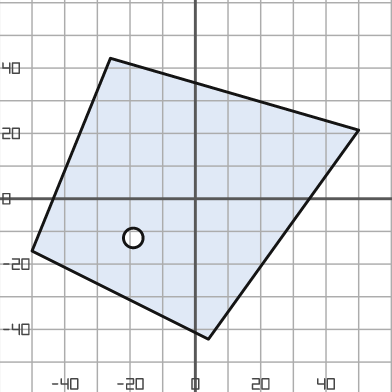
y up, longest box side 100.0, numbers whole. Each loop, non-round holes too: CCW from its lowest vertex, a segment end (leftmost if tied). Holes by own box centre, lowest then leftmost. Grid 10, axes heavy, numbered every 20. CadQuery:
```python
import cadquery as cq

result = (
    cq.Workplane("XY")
    .moveTo(4.0, -43.0)
    .lineTo(50.0, 21.0)
    .lineTo(-26.0, 43.0)
    .lineTo(-50.0, -16.0)
    .close()
    .moveTo(-19.0, -12.0)
    .circle(3.0)
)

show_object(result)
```